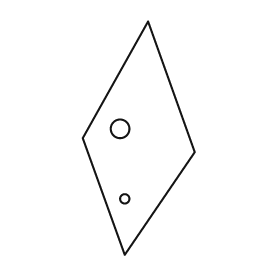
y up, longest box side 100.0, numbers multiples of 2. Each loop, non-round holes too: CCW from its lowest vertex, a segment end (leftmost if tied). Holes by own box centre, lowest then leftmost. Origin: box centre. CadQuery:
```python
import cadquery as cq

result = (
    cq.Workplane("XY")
    .moveTo(-6.0, -50.0)
    .lineTo(24.0, -6.0)
    .lineTo(4.0, 50.0)
    .lineTo(-24.0, 0.0)
    .close()
    .moveTo(-6.0, -26.0)
    .circle(2.0)
    .moveTo(-8.0, 4.0)
    .circle(4.0)
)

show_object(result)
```